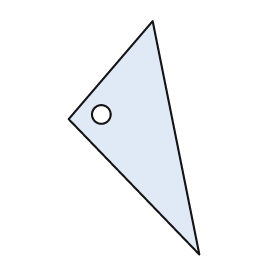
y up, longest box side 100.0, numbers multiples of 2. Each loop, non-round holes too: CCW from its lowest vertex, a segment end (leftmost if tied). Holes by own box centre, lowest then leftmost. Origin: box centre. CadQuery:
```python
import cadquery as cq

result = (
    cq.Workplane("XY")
    .moveTo(28.0, -50.0)
    .lineTo(8.0, 50.0)
    .lineTo(-28.0, 8.0)
    .close()
    .moveTo(-14.0, 10.0)
    .circle(4.0)
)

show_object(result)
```